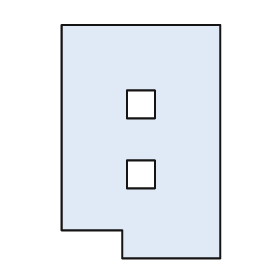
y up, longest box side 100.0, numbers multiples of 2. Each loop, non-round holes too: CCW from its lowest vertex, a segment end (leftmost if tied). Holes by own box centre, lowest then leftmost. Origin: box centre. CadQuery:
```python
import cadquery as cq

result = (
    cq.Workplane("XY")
    .moveTo(-8.0, -50.0)
    .lineTo(34.0, -50.0)
    .lineTo(34.0, 50.0)
    .lineTo(-34.0, 50.0)
    .lineTo(-34.0, -38.0)
    .lineTo(-8.0, -38.0)
    .close()
    .moveTo(-6.0, -20.0)
    .lineTo(6.0, -20.0)
    .lineTo(6.0, -8.0)
    .lineTo(-6.0, -8.0)
    .close()
    .moveTo(-6.0, 10.0)
    .lineTo(6.0, 10.0)
    .lineTo(6.0, 22.0)
    .lineTo(-6.0, 22.0)
    .close()
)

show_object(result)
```